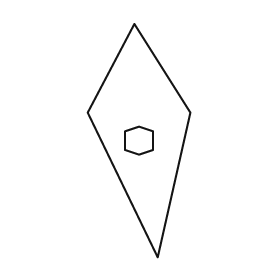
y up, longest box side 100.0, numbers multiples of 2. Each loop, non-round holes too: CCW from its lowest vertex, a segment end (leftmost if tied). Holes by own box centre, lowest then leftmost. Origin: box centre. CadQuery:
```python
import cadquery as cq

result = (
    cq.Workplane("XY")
    .moveTo(8.0, -50.0)
    .lineTo(22.0, 12.0)
    .lineTo(-2.0, 50.0)
    .lineTo(-22.0, 12.0)
    .close()
    .moveTo(0.0, -6.0)
    .lineTo(6.0, -4.0)
    .lineTo(6.0, 4.0)
    .lineTo(0.0, 6.0)
    .lineTo(-6.0, 4.0)
    .lineTo(-6.0, -4.0)
    .close()
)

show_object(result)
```